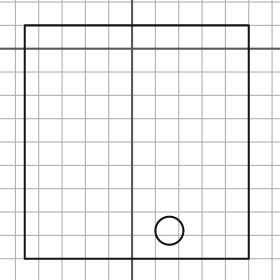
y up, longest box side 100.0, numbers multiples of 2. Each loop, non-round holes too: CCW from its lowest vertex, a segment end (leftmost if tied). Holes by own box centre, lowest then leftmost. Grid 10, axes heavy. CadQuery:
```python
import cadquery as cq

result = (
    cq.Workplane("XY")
    .moveTo(-46.0, -90.0)
    .lineTo(50.0, -90.0)
    .lineTo(50.0, 10.0)
    .lineTo(-46.0, 10.0)
    .close()
    .moveTo(16.0, -78.0)
    .circle(6.0)
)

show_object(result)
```